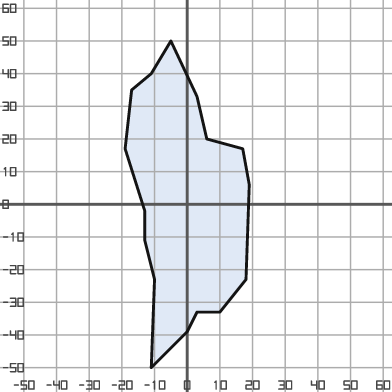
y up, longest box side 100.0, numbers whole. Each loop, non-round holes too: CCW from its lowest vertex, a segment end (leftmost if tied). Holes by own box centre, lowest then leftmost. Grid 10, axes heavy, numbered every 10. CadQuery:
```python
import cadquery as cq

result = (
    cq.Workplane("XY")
    .moveTo(-11.0, -50.0)
    .lineTo(0.0, -39.0)
    .lineTo(3.0, -33.0)
    .lineTo(10.0, -33.0)
    .lineTo(18.0, -23.0)
    .lineTo(19.0, 6.0)
    .lineTo(17.0, 17.0)
    .lineTo(6.0, 20.0)
    .lineTo(3.0, 33.0)
    .lineTo(-5.0, 50.0)
    .lineTo(-11.0, 40.0)
    .lineTo(-17.0, 35.0)
    .lineTo(-19.0, 17.0)
    .lineTo(-13.0, -2.0)
    .lineTo(-13.0, -11.0)
    .lineTo(-10.0, -23.0)
    .close()
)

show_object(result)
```